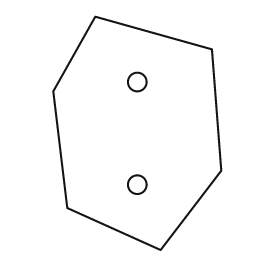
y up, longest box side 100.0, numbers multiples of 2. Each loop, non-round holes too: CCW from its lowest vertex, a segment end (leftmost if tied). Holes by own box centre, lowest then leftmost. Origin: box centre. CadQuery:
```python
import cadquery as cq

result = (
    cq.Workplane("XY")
    .moveTo(10.0, -50.0)
    .lineTo(36.0, -16.0)
    .lineTo(32.0, 36.0)
    .lineTo(-18.0, 50.0)
    .lineTo(-36.0, 18.0)
    .lineTo(-30.0, -32.0)
    .close()
    .moveTo(0.0, -22.0)
    .circle(4.0)
    .moveTo(0.0, 22.0)
    .circle(4.0)
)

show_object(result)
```